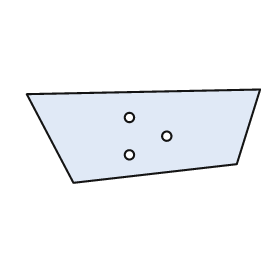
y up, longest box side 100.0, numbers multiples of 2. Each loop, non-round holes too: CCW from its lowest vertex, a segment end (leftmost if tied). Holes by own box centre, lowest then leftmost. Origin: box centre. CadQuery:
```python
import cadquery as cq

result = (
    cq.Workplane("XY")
    .moveTo(-30.0, -20.0)
    .lineTo(40.0, -12.0)
    .lineTo(50.0, 20.0)
    .lineTo(-50.0, 18.0)
    .close()
    .moveTo(-6.0, -8.0)
    .circle(2.0)
    .moveTo(10.0, 0.0)
    .circle(2.0)
    .moveTo(-6.0, 8.0)
    .circle(2.0)
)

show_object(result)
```